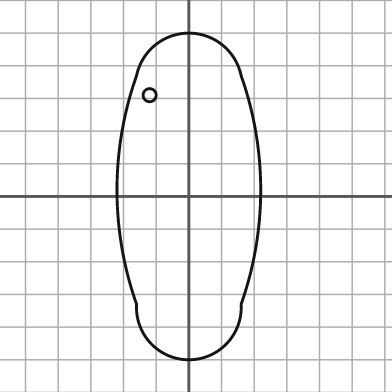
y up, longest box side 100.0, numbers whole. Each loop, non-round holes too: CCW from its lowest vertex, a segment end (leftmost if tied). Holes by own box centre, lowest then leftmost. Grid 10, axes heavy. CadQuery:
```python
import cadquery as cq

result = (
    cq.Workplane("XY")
    .moveTo(-16.0, -33.0)
    .threePointArc((0.0, -50.0), (16.0, -33.0))
    .threePointArc((22.0, 2.0), (16.0, 37.0))
    .threePointArc((0.0, 50.0), (-16.0, 37.0))
    .threePointArc((-22.0, 2.0), (-16.0, -33.0))
    .close()
    .moveTo(-12.0, 31.0)
    .circle(2.0)
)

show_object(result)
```